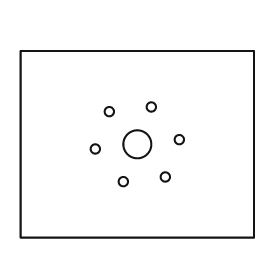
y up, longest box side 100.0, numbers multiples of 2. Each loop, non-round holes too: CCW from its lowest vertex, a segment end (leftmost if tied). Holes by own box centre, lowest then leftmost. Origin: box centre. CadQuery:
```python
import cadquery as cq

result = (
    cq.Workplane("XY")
    .moveTo(-50.0, -40.0)
    .lineTo(50.0, -40.0)
    .lineTo(50.0, 40.0)
    .lineTo(-50.0, 40.0)
    .close()
    .moveTo(-6.0, -16.0)
    .circle(2.0)
    .moveTo(12.0, -14.0)
    .circle(2.0)
    .moveTo(-18.0, -2.0)
    .circle(2.0)
    .moveTo(0.0, 0.0)
    .circle(6.0)
    .moveTo(18.0, 2.0)
    .circle(2.0)
    .moveTo(-12.0, 14.0)
    .circle(2.0)
    .moveTo(6.0, 16.0)
    .circle(2.0)
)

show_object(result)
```